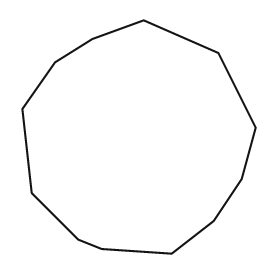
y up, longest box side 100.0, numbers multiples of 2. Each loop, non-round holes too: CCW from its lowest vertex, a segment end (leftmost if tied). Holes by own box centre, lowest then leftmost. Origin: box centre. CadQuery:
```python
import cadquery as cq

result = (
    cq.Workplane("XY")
    .moveTo(14.0, -50.0)
    .lineTo(32.0, -36.0)
    .lineTo(44.0, -18.0)
    .lineTo(50.0, 4.0)
    .lineTo(34.0, 36.0)
    .lineTo(2.0, 50.0)
    .lineTo(-20.0, 42.0)
    .lineTo(-36.0, 32.0)
    .lineTo(-50.0, 12.0)
    .lineTo(-46.0, -24.0)
    .lineTo(-26.0, -44.0)
    .lineTo(-16.0, -48.0)
    .close()
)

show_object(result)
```